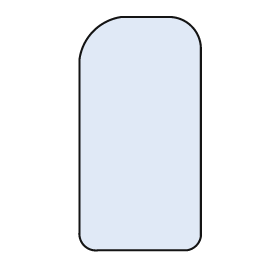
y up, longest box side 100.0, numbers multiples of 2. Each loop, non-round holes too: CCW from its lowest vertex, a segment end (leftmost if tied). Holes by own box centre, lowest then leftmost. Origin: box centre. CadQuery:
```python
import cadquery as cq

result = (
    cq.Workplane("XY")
    .moveTo(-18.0, -50.0)
    .lineTo(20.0, -50.0)
    .threePointArc((24.0, -48.0), (26.0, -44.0))
    .lineTo(26.0, 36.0)
    .threePointArc((22.0, 46.0), (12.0, 50.0))
    .lineTo(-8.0, 50.0)
    .threePointArc((-20.0, 44.0), (-26.0, 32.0))
    .lineTo(-26.0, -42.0)
    .threePointArc((-24.0, -48.0), (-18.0, -50.0))
    .close()
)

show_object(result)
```